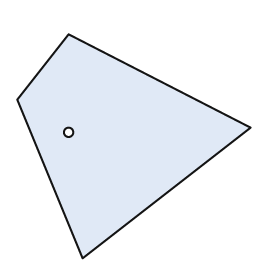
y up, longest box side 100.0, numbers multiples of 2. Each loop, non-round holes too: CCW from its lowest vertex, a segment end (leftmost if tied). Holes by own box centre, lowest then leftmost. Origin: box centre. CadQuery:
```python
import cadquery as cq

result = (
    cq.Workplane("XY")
    .moveTo(-22.0, -48.0)
    .lineTo(50.0, 8.0)
    .lineTo(-28.0, 48.0)
    .lineTo(-50.0, 20.0)
    .close()
    .moveTo(-28.0, 6.0)
    .circle(2.0)
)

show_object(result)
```